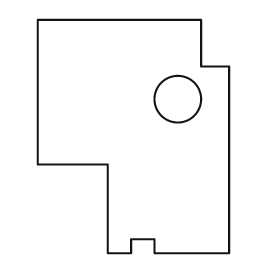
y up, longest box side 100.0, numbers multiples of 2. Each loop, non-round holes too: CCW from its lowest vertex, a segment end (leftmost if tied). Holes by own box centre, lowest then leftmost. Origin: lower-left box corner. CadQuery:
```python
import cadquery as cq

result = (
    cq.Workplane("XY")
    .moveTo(30.0, 0.0)
    .lineTo(40.0, 0.0)
    .lineTo(40.0, 6.0)
    .lineTo(50.0, 6.0)
    .lineTo(50.0, 0.0)
    .lineTo(82.0, 0.0)
    .lineTo(82.0, 80.0)
    .lineTo(70.0, 80.0)
    .lineTo(70.0, 100.0)
    .lineTo(0.0, 100.0)
    .lineTo(0.0, 38.0)
    .lineTo(30.0, 38.0)
    .close()
    .moveTo(60.0, 66.0)
    .circle(10.0)
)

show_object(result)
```